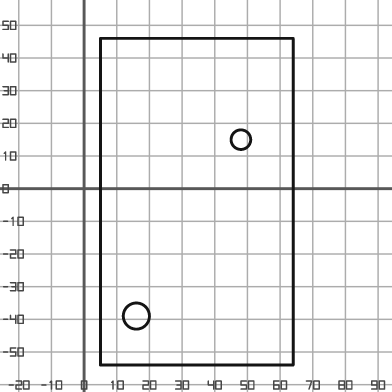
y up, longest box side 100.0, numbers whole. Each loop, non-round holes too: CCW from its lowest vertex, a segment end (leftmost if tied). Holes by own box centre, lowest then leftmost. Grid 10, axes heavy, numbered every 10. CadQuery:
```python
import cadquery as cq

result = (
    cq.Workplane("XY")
    .moveTo(5.0, -54.0)
    .lineTo(64.0, -54.0)
    .lineTo(64.0, 46.0)
    .lineTo(5.0, 46.0)
    .close()
    .moveTo(16.0, -39.0)
    .circle(4.0)
    .moveTo(48.0, 15.0)
    .circle(3.0)
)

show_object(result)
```